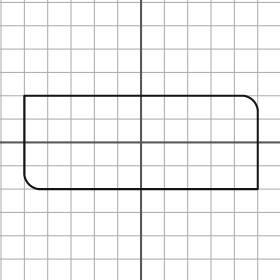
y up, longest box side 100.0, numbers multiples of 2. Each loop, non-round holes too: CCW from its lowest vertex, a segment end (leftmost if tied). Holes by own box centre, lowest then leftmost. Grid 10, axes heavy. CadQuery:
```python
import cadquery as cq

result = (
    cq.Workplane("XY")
    .moveTo(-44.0, -20.0)
    .lineTo(50.0, -20.0)
    .lineTo(50.0, 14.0)
    .threePointArc((48.0, 18.0), (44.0, 20.0))
    .lineTo(-50.0, 20.0)
    .lineTo(-50.0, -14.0)
    .threePointArc((-48.0, -18.0), (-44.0, -20.0))
    .close()
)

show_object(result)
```